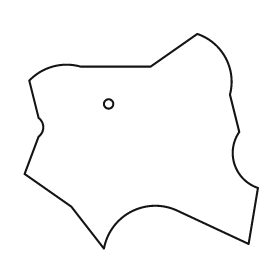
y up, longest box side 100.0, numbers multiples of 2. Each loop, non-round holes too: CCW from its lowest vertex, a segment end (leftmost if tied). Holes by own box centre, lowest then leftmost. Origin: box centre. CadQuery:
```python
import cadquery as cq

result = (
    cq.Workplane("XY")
    .moveTo(-16.0, -46.0)
    .threePointArc((-4.0, -30.0), (16.0, -30.0))
    .lineTo(46.0, -44.0)
    .lineTo(50.0, -20.0)
    .threePointArc((40.0, -10.0), (42.0, 4.0))
    .lineTo(38.0, 20.0)
    .threePointArc((36.0, 36.0), (24.0, 46.0))
    .lineTo(4.0, 32.0)
    .lineTo(-26.0, 32.0)
    .threePointArc((-38.0, 32.0), (-48.0, 26.0))
    .lineTo(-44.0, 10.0)
    .threePointArc((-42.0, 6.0), (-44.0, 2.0))
    .lineTo(-50.0, -14.0)
    .lineTo(-30.0, -28.0)
    .close()
    .moveTo(-14.0, 16.0)
    .circle(2.0)
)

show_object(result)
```